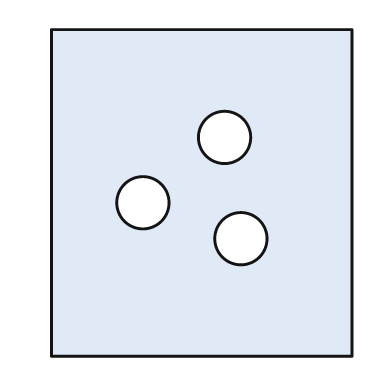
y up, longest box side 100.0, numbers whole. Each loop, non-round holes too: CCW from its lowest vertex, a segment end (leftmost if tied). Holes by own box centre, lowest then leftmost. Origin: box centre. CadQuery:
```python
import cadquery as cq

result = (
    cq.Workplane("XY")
    .moveTo(-46.0, -50.0)
    .lineTo(46.0, -50.0)
    .lineTo(46.0, 50.0)
    .lineTo(-46.0, 50.0)
    .close()
    .moveTo(12.0, -14.0)
    .circle(8.0)
    .moveTo(-18.0, -3.0)
    .circle(8.0)
    .moveTo(7.0, 17.0)
    .circle(8.0)
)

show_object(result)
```